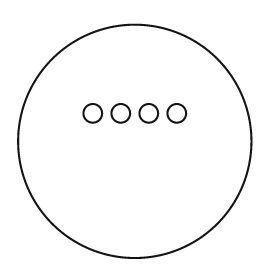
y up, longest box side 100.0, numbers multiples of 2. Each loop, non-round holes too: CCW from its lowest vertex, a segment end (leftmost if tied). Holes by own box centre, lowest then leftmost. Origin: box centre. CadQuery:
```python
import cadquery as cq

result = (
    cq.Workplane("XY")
    .moveTo(0.0, 0.0)
    .circle(50.0)
    .moveTo(-18.0, 12.0)
    .circle(4.0)
    .moveTo(-6.0, 12.0)
    .circle(4.0)
    .moveTo(6.0, 12.0)
    .circle(4.0)
    .moveTo(18.0, 12.0)
    .circle(4.0)
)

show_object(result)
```